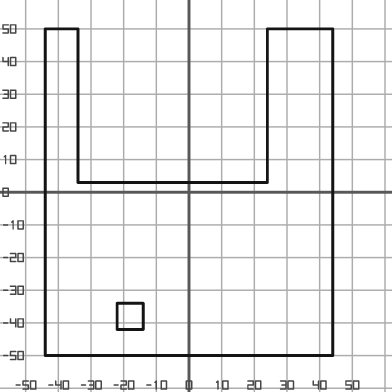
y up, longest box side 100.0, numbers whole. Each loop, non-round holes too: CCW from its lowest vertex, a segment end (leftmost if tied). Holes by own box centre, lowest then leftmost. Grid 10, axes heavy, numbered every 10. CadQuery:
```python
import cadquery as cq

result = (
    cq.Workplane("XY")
    .moveTo(-44.0, -50.0)
    .lineTo(44.0, -50.0)
    .lineTo(44.0, 50.0)
    .lineTo(24.0, 50.0)
    .lineTo(24.0, 3.0)
    .lineTo(-34.0, 3.0)
    .lineTo(-34.0, 50.0)
    .lineTo(-44.0, 50.0)
    .close()
    .moveTo(-22.0, -42.0)
    .lineTo(-14.0, -42.0)
    .lineTo(-14.0, -34.0)
    .lineTo(-22.0, -34.0)
    .close()
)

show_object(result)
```